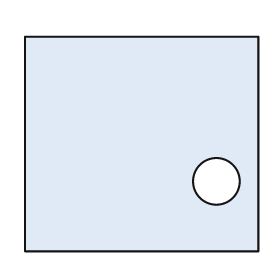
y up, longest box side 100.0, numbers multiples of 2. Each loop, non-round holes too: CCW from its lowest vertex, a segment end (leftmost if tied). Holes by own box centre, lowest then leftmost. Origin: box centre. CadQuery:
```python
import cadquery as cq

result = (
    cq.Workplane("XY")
    .moveTo(-50.0, -46.0)
    .lineTo(50.0, -46.0)
    .lineTo(50.0, 46.0)
    .lineTo(-50.0, 46.0)
    .close()
    .moveTo(32.0, -16.0)
    .circle(10.0)
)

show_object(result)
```